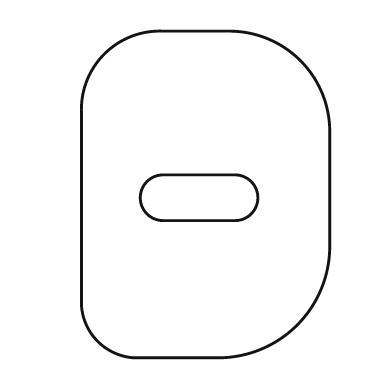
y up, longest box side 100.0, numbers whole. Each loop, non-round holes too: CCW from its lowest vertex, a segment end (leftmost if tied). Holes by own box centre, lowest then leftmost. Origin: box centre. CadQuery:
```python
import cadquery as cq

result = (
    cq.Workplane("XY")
    .moveTo(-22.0, -50.0)
    .lineTo(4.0, -50.0)
    .threePointArc((28.0, -40.0), (38.0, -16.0))
    .lineTo(38.0, 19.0)
    .threePointArc((29.0, 41.0), (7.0, 50.0))
    .lineTo(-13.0, 50.0)
    .threePointArc((-31.0, 43.0), (-38.0, 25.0))
    .lineTo(-38.0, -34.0)
    .threePointArc((-33.0, -45.0), (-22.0, -50.0))
    .close()
    .moveTo(-13.0, -8.0)
    .lineTo(9.0, -8.0)
    .threePointArc((16.0, -1.0), (9.0, 6.0))
    .lineTo(-13.0, 6.0)
    .threePointArc((-20.0, -1.0), (-13.0, -8.0))
    .close()
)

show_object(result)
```